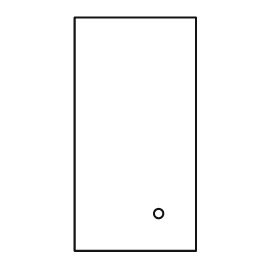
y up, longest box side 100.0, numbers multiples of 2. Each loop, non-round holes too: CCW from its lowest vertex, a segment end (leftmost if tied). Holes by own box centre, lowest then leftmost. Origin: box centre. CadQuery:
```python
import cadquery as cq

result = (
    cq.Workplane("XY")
    .moveTo(-26.0, -50.0)
    .lineTo(26.0, -50.0)
    .lineTo(26.0, 50.0)
    .lineTo(-26.0, 50.0)
    .close()
    .moveTo(10.0, -34.0)
    .circle(2.0)
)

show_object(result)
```